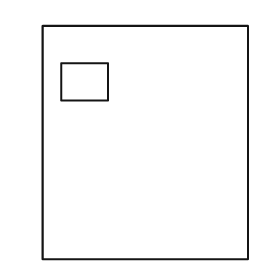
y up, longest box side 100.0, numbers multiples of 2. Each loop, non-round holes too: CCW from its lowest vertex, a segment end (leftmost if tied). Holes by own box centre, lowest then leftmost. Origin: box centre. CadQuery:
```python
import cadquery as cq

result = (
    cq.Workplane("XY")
    .moveTo(-44.0, -50.0)
    .lineTo(44.0, -50.0)
    .lineTo(44.0, 50.0)
    .lineTo(-44.0, 50.0)
    .close()
    .moveTo(-36.0, 18.0)
    .lineTo(-16.0, 18.0)
    .lineTo(-16.0, 34.0)
    .lineTo(-36.0, 34.0)
    .close()
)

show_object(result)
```